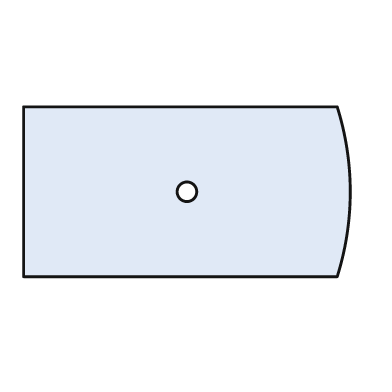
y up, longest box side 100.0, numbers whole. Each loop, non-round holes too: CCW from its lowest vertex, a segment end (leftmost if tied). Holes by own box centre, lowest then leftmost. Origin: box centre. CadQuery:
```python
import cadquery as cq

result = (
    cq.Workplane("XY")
    .moveTo(-50.0, -26.0)
    .lineTo(46.0, -26.0)
    .threePointArc((50.0, 0.0), (46.0, 26.0))
    .lineTo(-50.0, 26.0)
    .close()
    .moveTo(0.0, 0.0)
    .circle(3.0)
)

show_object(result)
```